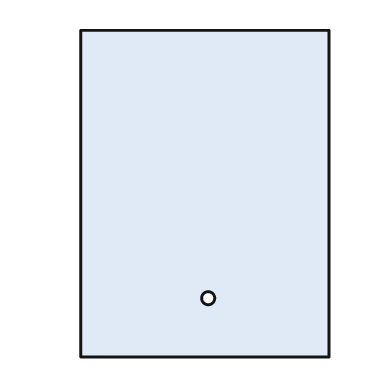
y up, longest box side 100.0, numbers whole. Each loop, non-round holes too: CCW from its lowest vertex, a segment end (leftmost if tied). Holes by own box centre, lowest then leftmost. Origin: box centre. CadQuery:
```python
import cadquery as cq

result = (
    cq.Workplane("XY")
    .moveTo(-38.0, -50.0)
    .lineTo(38.0, -50.0)
    .lineTo(38.0, 50.0)
    .lineTo(-38.0, 50.0)
    .close()
    .moveTo(1.0, -32.0)
    .circle(2.0)
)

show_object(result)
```